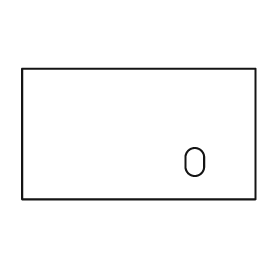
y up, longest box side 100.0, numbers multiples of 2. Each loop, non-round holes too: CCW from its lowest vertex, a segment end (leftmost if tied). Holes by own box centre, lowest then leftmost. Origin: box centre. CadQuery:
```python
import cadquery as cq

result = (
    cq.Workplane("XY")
    .moveTo(-50.0, -28.0)
    .lineTo(50.0, -28.0)
    .lineTo(50.0, 28.0)
    .lineTo(-50.0, 28.0)
    .close()
    .moveTo(20.0, -14.0)
    .threePointArc((24.0, -18.0), (28.0, -14.0))
    .lineTo(28.0, -10.0)
    .threePointArc((24.0, -6.0), (20.0, -10.0))
    .close()
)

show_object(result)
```